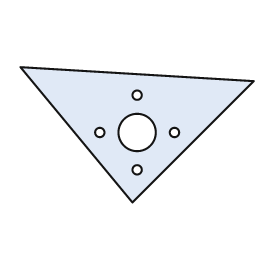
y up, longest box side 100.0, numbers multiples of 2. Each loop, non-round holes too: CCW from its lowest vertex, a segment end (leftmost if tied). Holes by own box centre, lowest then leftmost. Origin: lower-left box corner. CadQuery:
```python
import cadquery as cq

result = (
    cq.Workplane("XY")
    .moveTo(48.0, 0.0)
    .lineTo(100.0, 52.0)
    .lineTo(0.0, 58.0)
    .close()
    .moveTo(50.0, 14.0)
    .circle(2.0)
    .moveTo(34.0, 30.0)
    .circle(2.0)
    .moveTo(50.0, 30.0)
    .circle(8.0)
    .moveTo(66.0, 30.0)
    .circle(2.0)
    .moveTo(50.0, 46.0)
    .circle(2.0)
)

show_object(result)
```